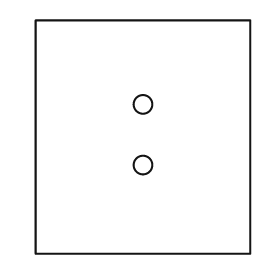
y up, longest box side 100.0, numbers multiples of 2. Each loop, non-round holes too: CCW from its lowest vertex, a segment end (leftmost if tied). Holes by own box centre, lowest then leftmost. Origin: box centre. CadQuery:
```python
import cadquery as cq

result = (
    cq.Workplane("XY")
    .moveTo(-46.0, -50.0)
    .lineTo(46.0, -50.0)
    .lineTo(46.0, 50.0)
    .lineTo(-46.0, 50.0)
    .close()
    .moveTo(0.0, -12.0)
    .circle(4.0)
    .moveTo(0.0, 14.0)
    .circle(4.0)
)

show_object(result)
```